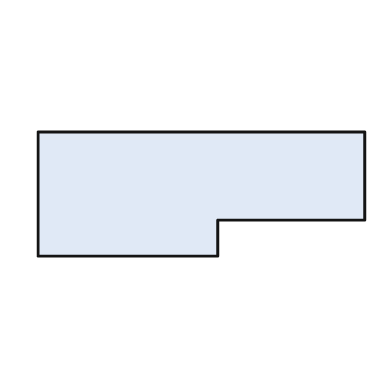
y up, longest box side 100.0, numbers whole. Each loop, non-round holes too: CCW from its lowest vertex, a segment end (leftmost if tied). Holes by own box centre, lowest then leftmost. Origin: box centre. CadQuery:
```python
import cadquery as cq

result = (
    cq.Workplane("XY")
    .moveTo(-50.0, -19.0)
    .lineTo(5.0, -19.0)
    .lineTo(5.0, -8.0)
    .lineTo(50.0, -8.0)
    .lineTo(50.0, 19.0)
    .lineTo(-50.0, 19.0)
    .close()
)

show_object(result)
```